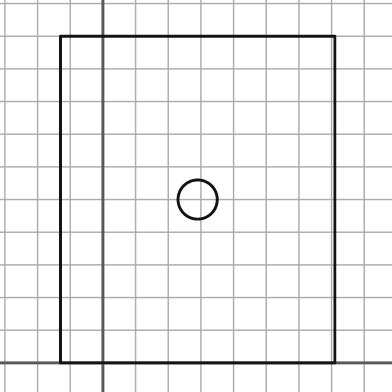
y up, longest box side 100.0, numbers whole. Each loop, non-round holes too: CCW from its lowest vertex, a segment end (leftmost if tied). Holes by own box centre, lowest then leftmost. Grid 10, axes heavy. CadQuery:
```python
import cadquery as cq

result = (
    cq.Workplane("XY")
    .moveTo(-13.0, 0.0)
    .lineTo(71.0, 0.0)
    .lineTo(71.0, 100.0)
    .lineTo(-13.0, 100.0)
    .close()
    .moveTo(29.0, 50.0)
    .circle(6.0)
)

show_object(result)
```